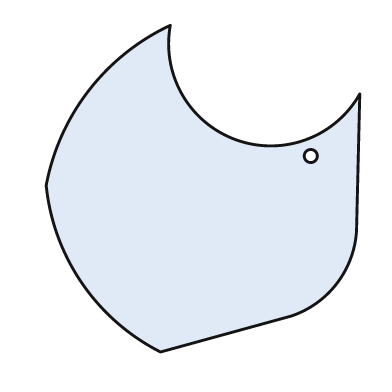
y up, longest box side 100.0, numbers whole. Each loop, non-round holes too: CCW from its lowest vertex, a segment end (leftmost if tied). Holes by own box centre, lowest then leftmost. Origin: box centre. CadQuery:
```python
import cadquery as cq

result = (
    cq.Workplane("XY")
    .moveTo(-13.0, -50.0)
    .lineTo(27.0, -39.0)
    .threePointArc((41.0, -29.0), (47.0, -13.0))
    .lineTo(48.0, 29.0)
    .threePointArc((10.0, 15.0), (-10.0, 50.0))
    .threePointArc((-35.0, 30.0), (-48.0, 1.0))
    .threePointArc((-37.0, -29.0), (-13.0, -50.0))
    .close()
    .moveTo(33.0, 10.0)
    .circle(2.0)
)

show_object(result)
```